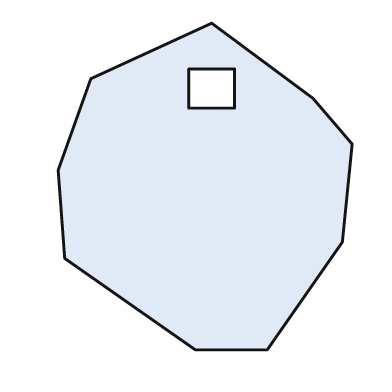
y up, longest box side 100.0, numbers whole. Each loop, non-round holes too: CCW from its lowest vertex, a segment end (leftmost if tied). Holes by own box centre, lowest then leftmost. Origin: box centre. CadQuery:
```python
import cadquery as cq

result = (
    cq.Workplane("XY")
    .moveTo(-3.0, -50.0)
    .lineTo(19.0, -50.0)
    .lineTo(42.0, -17.0)
    .lineTo(45.0, 13.0)
    .lineTo(33.0, 27.0)
    .lineTo(2.0, 50.0)
    .lineTo(-35.0, 33.0)
    .lineTo(-45.0, 5.0)
    .lineTo(-43.0, -22.0)
    .close()
    .moveTo(-5.0, 24.0)
    .lineTo(9.0, 24.0)
    .lineTo(9.0, 36.0)
    .lineTo(-5.0, 36.0)
    .close()
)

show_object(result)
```